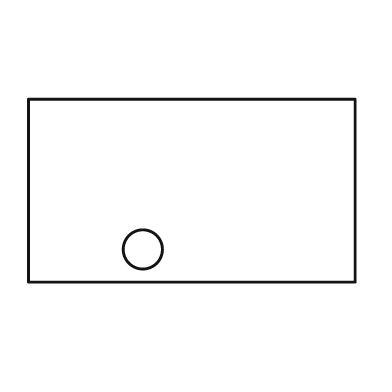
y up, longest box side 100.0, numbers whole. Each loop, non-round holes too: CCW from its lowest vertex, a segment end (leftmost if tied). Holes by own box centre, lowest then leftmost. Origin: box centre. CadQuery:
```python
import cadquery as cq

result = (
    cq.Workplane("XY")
    .moveTo(-50.0, -28.0)
    .lineTo(50.0, -28.0)
    .lineTo(50.0, 28.0)
    .lineTo(-50.0, 28.0)
    .close()
    .moveTo(-15.0, -18.0)
    .circle(6.0)
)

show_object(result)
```